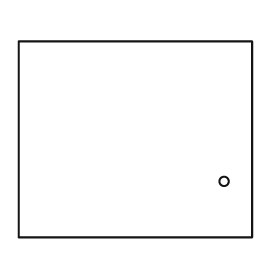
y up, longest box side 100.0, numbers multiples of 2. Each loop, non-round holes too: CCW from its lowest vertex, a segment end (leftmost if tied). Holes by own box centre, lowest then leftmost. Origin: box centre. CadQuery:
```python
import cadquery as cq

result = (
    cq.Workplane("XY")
    .moveTo(-50.0, -42.0)
    .lineTo(50.0, -42.0)
    .lineTo(50.0, 42.0)
    .lineTo(-50.0, 42.0)
    .close()
    .moveTo(38.0, -18.0)
    .circle(2.0)
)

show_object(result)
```